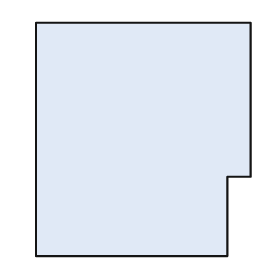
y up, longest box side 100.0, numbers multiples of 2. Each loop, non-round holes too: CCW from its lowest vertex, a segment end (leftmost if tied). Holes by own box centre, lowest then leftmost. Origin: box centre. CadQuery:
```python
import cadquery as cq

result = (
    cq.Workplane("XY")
    .moveTo(-46.0, -50.0)
    .lineTo(36.0, -50.0)
    .lineTo(36.0, -16.0)
    .lineTo(46.0, -16.0)
    .lineTo(46.0, 50.0)
    .lineTo(-46.0, 50.0)
    .close()
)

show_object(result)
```